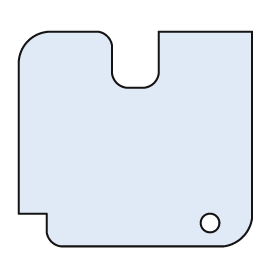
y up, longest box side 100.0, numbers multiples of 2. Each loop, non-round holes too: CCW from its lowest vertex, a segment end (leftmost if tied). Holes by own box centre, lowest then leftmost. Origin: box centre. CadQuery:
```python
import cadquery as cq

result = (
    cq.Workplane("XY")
    .moveTo(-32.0, -46.0)
    .lineTo(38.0, -46.0)
    .threePointArc((46.0, -42.0), (50.0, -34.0))
    .lineTo(50.0, 46.0)
    .lineTo(10.0, 46.0)
    .lineTo(10.0, 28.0)
    .threePointArc((8.0, 24.0), (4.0, 22.0))
    .lineTo(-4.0, 22.0)
    .threePointArc((-8.0, 24.0), (-10.0, 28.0))
    .lineTo(-10.0, 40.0)
    .threePointArc((-12.0, 44.0), (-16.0, 46.0))
    .lineTo(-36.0, 46.0)
    .threePointArc((-46.0, 42.0), (-50.0, 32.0))
    .lineTo(-50.0, -32.0)
    .lineTo(-38.0, -32.0)
    .lineTo(-38.0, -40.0)
    .threePointArc((-36.0, -44.0), (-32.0, -46.0))
    .close()
    .moveTo(32.0, -36.0)
    .circle(4.0)
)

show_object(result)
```